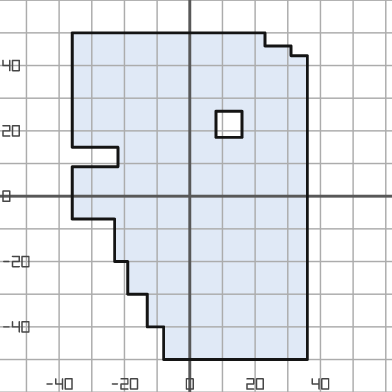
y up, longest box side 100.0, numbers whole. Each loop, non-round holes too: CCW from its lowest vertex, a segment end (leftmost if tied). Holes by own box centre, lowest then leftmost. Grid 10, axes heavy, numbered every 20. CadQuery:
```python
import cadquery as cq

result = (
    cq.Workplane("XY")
    .moveTo(-8.0, -50.0)
    .lineTo(36.0, -50.0)
    .lineTo(36.0, 43.0)
    .lineTo(31.0, 43.0)
    .lineTo(31.0, 46.0)
    .lineTo(23.0, 46.0)
    .lineTo(23.0, 50.0)
    .lineTo(-36.0, 50.0)
    .lineTo(-36.0, 15.0)
    .lineTo(-22.0, 15.0)
    .lineTo(-22.0, 9.0)
    .lineTo(-36.0, 9.0)
    .lineTo(-36.0, -7.0)
    .lineTo(-23.0, -7.0)
    .lineTo(-23.0, -20.0)
    .lineTo(-19.0, -20.0)
    .lineTo(-19.0, -30.0)
    .lineTo(-13.0, -30.0)
    .lineTo(-13.0, -40.0)
    .lineTo(-8.0, -40.0)
    .close()
    .moveTo(8.0, 18.0)
    .lineTo(16.0, 18.0)
    .lineTo(16.0, 26.0)
    .lineTo(8.0, 26.0)
    .close()
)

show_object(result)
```